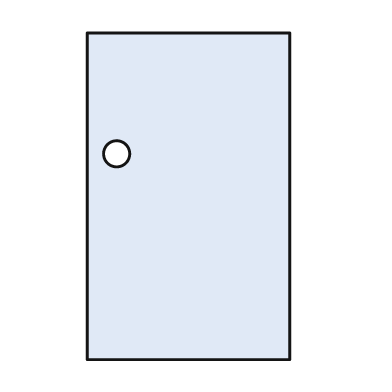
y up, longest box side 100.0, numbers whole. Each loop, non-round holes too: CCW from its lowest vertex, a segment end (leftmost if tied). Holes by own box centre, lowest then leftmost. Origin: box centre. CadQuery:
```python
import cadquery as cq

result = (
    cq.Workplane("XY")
    .moveTo(-31.0, -50.0)
    .lineTo(31.0, -50.0)
    .lineTo(31.0, 50.0)
    .lineTo(-31.0, 50.0)
    .close()
    .moveTo(-22.0, 13.0)
    .circle(4.0)
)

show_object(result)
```